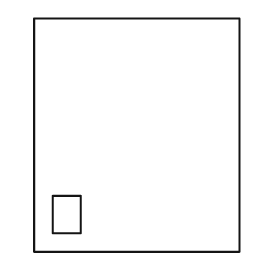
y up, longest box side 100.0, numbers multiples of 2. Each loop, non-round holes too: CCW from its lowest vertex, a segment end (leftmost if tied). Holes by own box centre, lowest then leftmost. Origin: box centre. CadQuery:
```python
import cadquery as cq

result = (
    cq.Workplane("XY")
    .moveTo(-44.0, -50.0)
    .lineTo(44.0, -50.0)
    .lineTo(44.0, 50.0)
    .lineTo(-44.0, 50.0)
    .close()
    .moveTo(-36.0, -42.0)
    .lineTo(-24.0, -42.0)
    .lineTo(-24.0, -26.0)
    .lineTo(-36.0, -26.0)
    .close()
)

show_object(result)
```